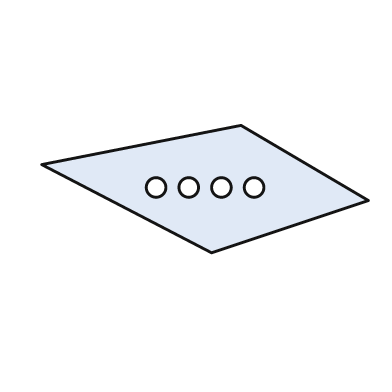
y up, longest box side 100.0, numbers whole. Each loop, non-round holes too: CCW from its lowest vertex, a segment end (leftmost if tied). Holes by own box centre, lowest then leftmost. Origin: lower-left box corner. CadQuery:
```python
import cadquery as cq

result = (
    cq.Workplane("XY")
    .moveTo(52.0, 0.0)
    .lineTo(100.0, 16.0)
    .lineTo(61.0, 39.0)
    .lineTo(0.0, 27.0)
    .close()
    .moveTo(35.0, 20.0)
    .circle(3.0)
    .moveTo(45.0, 20.0)
    .circle(3.0)
    .moveTo(55.0, 20.0)
    .circle(3.0)
    .moveTo(65.0, 20.0)
    .circle(3.0)
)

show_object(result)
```